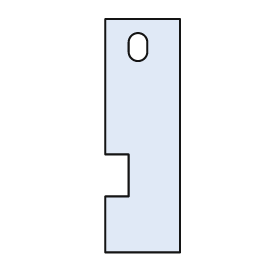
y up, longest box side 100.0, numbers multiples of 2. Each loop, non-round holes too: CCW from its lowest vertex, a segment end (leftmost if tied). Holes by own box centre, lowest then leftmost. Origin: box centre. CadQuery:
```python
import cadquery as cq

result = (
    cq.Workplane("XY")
    .moveTo(-16.0, -50.0)
    .lineTo(16.0, -50.0)
    .lineTo(16.0, 50.0)
    .lineTo(-16.0, 50.0)
    .lineTo(-16.0, -8.0)
    .lineTo(-6.0, -8.0)
    .lineTo(-6.0, -26.0)
    .lineTo(-16.0, -26.0)
    .close()
    .moveTo(-6.0, 36.0)
    .threePointArc((-2.0, 32.0), (2.0, 36.0))
    .lineTo(2.0, 40.0)
    .threePointArc((-2.0, 44.0), (-6.0, 40.0))
    .close()
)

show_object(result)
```